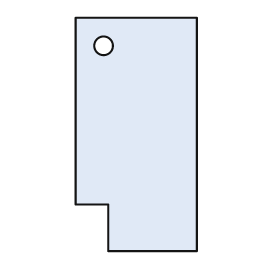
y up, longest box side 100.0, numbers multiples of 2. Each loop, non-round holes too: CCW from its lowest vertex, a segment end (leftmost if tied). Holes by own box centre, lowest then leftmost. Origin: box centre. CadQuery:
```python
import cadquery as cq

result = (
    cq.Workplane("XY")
    .moveTo(-12.0, -50.0)
    .lineTo(26.0, -50.0)
    .lineTo(26.0, 50.0)
    .lineTo(-26.0, 50.0)
    .lineTo(-26.0, -30.0)
    .lineTo(-12.0, -30.0)
    .close()
    .moveTo(-14.0, 38.0)
    .circle(4.0)
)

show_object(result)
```